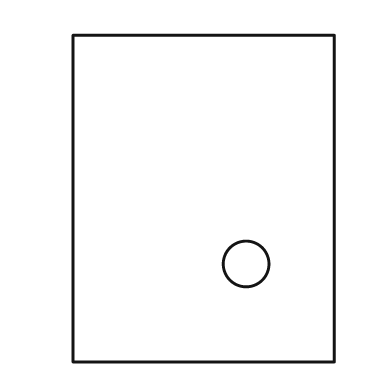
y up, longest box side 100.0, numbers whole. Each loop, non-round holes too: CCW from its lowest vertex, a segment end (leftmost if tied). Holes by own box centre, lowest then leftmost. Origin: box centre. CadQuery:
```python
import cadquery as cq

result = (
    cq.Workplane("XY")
    .moveTo(-40.0, -50.0)
    .lineTo(40.0, -50.0)
    .lineTo(40.0, 50.0)
    .lineTo(-40.0, 50.0)
    .close()
    .moveTo(13.0, -20.0)
    .circle(7.0)
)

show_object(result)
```